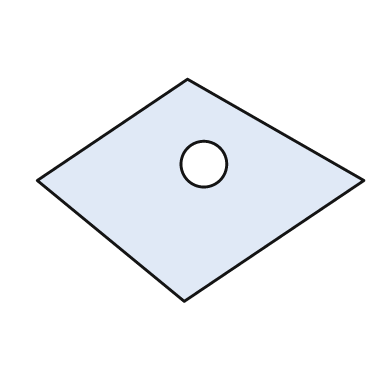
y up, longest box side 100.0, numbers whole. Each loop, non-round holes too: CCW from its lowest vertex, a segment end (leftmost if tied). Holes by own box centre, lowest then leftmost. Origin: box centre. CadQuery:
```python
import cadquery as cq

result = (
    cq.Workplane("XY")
    .moveTo(-5.0, -34.0)
    .lineTo(50.0, 3.0)
    .lineTo(-4.0, 34.0)
    .lineTo(-50.0, 3.0)
    .close()
    .moveTo(1.0, 8.0)
    .circle(7.0)
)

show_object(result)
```